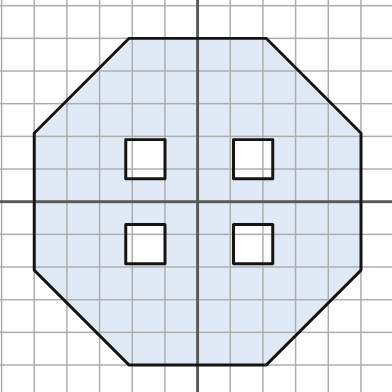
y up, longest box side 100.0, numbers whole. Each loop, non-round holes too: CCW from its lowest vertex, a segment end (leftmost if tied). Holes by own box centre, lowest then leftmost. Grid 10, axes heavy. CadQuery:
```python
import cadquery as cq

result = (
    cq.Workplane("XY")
    .moveTo(-21.0, -50.0)
    .lineTo(21.0, -50.0)
    .lineTo(50.0, -21.0)
    .lineTo(50.0, 21.0)
    .lineTo(21.0, 50.0)
    .lineTo(-21.0, 50.0)
    .lineTo(-50.0, 21.0)
    .lineTo(-50.0, -21.0)
    .close()
    .moveTo(-22.0, -19.0)
    .lineTo(-10.0, -19.0)
    .lineTo(-10.0, -7.0)
    .lineTo(-22.0, -7.0)
    .close()
    .moveTo(11.0, -19.0)
    .lineTo(23.0, -19.0)
    .lineTo(23.0, -7.0)
    .lineTo(11.0, -7.0)
    .close()
    .moveTo(-22.0, 7.0)
    .lineTo(-10.0, 7.0)
    .lineTo(-10.0, 19.0)
    .lineTo(-22.0, 19.0)
    .close()
    .moveTo(11.0, 7.0)
    .lineTo(23.0, 7.0)
    .lineTo(23.0, 19.0)
    .lineTo(11.0, 19.0)
    .close()
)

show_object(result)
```